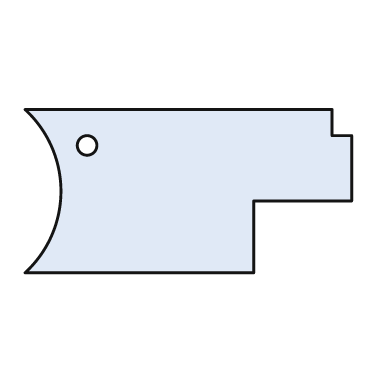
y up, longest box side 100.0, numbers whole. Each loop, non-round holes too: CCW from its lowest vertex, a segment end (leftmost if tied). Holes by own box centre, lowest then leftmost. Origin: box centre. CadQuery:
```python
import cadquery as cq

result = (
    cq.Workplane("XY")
    .moveTo(-50.0, -25.0)
    .lineTo(20.0, -25.0)
    .lineTo(20.0, -3.0)
    .lineTo(50.0, -3.0)
    .lineTo(50.0, 17.0)
    .lineTo(44.0, 17.0)
    .lineTo(44.0, 25.0)
    .lineTo(-50.0, 25.0)
    .threePointArc((-39.0, 0.0), (-50.0, -25.0))
    .close()
    .moveTo(-31.0, 14.0)
    .circle(3.0)
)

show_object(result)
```